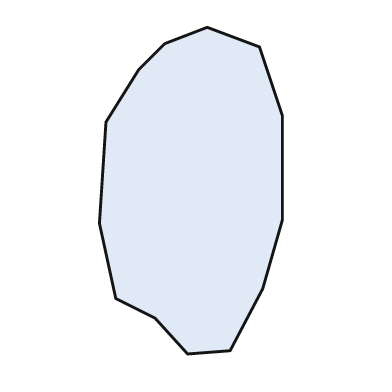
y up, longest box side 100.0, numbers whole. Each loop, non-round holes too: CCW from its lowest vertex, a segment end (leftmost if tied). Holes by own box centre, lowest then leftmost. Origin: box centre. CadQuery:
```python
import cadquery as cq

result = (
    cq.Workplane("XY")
    .moveTo(-1.0, -50.0)
    .lineTo(12.0, -49.0)
    .lineTo(22.0, -30.0)
    .lineTo(28.0, -9.0)
    .lineTo(28.0, 23.0)
    .lineTo(21.0, 44.0)
    .lineTo(5.0, 50.0)
    .lineTo(-8.0, 45.0)
    .lineTo(-16.0, 37.0)
    .lineTo(-26.0, 21.0)
    .lineTo(-28.0, -10.0)
    .lineTo(-23.0, -33.0)
    .lineTo(-11.0, -39.0)
    .close()
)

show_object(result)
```